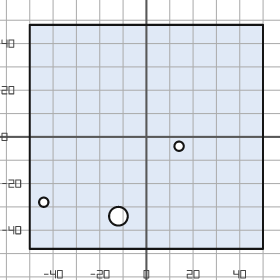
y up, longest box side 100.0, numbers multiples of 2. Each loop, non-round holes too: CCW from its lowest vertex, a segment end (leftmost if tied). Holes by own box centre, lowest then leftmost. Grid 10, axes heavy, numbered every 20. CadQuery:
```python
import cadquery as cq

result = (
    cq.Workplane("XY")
    .moveTo(-50.0, -48.0)
    .lineTo(50.0, -48.0)
    .lineTo(50.0, 48.0)
    .lineTo(-50.0, 48.0)
    .close()
    .moveTo(-12.0, -34.0)
    .circle(4.0)
    .moveTo(-44.0, -28.0)
    .circle(2.0)
    .moveTo(14.0, -4.0)
    .circle(2.0)
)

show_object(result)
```